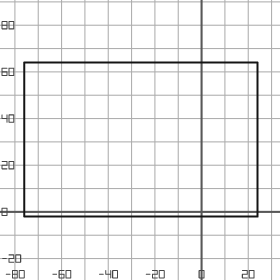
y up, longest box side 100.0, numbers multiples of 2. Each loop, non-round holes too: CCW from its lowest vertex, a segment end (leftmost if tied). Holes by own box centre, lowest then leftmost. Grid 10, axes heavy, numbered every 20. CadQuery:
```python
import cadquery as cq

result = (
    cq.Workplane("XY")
    .moveTo(-76.0, -2.0)
    .lineTo(24.0, -2.0)
    .lineTo(24.0, 64.0)
    .lineTo(-76.0, 64.0)
    .close()
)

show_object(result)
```